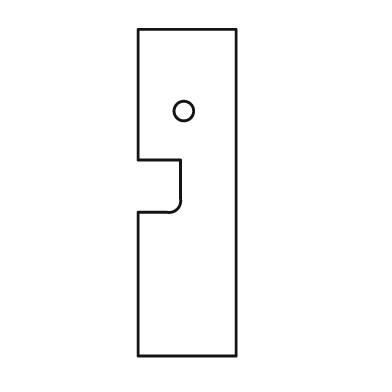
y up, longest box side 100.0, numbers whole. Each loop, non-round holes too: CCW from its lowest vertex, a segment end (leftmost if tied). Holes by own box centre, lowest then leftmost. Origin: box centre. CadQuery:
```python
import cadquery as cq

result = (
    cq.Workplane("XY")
    .moveTo(-15.0, -50.0)
    .lineTo(15.0, -50.0)
    .lineTo(15.0, 50.0)
    .lineTo(-15.0, 50.0)
    .lineTo(-15.0, 10.0)
    .lineTo(-2.0, 10.0)
    .lineTo(-2.0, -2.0)
    .threePointArc((-3.0, -5.0), (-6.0, -6.0))
    .lineTo(-15.0, -6.0)
    .close()
    .moveTo(-1.0, 25.0)
    .circle(3.0)
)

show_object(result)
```